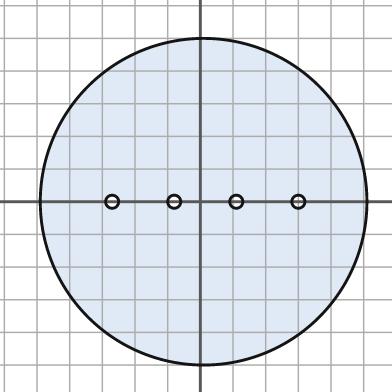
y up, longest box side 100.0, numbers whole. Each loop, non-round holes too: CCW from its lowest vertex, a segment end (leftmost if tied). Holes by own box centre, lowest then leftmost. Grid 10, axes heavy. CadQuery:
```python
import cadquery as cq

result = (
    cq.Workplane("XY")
    .moveTo(1.0, 0.0)
    .circle(50.0)
    .moveTo(-27.0, 0.0)
    .circle(2.0)
    .moveTo(-8.0, 0.0)
    .circle(2.0)
    .moveTo(11.0, 0.0)
    .circle(2.0)
    .moveTo(30.0, 0.0)
    .circle(2.0)
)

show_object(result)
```